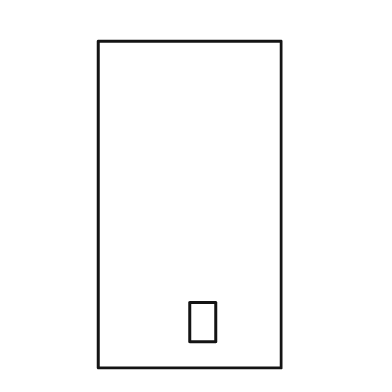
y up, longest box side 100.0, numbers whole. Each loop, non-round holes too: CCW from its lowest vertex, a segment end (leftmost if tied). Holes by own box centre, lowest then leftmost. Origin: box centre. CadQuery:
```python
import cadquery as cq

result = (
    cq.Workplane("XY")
    .moveTo(-28.0, -50.0)
    .lineTo(28.0, -50.0)
    .lineTo(28.0, 50.0)
    .lineTo(-28.0, 50.0)
    .close()
    .moveTo(0.0, -42.0)
    .lineTo(8.0, -42.0)
    .lineTo(8.0, -30.0)
    .lineTo(0.0, -30.0)
    .close()
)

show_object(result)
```